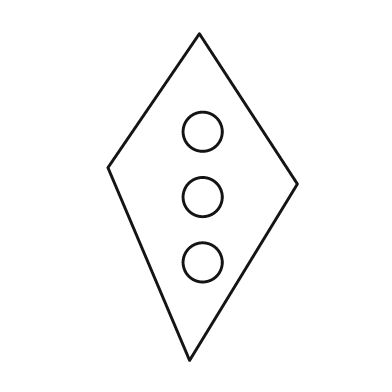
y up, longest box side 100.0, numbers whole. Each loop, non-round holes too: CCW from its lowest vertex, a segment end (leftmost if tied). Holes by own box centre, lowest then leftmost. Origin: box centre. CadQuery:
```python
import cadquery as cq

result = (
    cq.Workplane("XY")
    .moveTo(-4.0, -50.0)
    .lineTo(29.0, 4.0)
    .lineTo(-1.0, 50.0)
    .lineTo(-29.0, 9.0)
    .close()
    .moveTo(0.0, -20.0)
    .circle(6.0)
    .moveTo(0.0, 0.0)
    .circle(6.0)
    .moveTo(0.0, 20.0)
    .circle(6.0)
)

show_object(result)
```